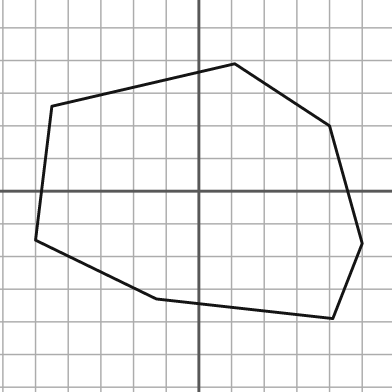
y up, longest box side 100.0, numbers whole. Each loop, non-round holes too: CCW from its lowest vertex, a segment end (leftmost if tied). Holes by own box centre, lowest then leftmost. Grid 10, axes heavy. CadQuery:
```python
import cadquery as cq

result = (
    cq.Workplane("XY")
    .moveTo(41.0, -39.0)
    .lineTo(50.0, -16.0)
    .lineTo(40.0, 20.0)
    .lineTo(11.0, 39.0)
    .lineTo(-45.0, 26.0)
    .lineTo(-50.0, -15.0)
    .lineTo(-13.0, -33.0)
    .close()
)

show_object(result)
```